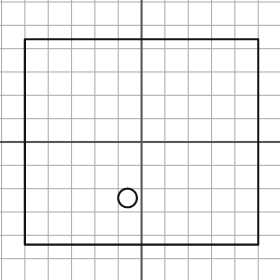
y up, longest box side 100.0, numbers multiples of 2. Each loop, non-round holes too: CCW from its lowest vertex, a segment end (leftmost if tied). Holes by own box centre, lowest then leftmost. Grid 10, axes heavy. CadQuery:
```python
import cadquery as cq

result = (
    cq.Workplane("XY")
    .moveTo(-50.0, -44.0)
    .lineTo(50.0, -44.0)
    .lineTo(50.0, 44.0)
    .lineTo(-50.0, 44.0)
    .close()
    .moveTo(-6.0, -24.0)
    .circle(4.0)
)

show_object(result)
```